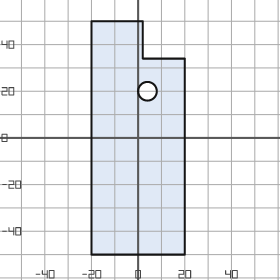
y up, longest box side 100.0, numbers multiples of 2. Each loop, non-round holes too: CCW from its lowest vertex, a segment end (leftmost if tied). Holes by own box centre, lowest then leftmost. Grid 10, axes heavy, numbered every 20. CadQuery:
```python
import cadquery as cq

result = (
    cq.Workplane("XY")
    .moveTo(-20.0, -50.0)
    .lineTo(20.0, -50.0)
    .lineTo(20.0, 34.0)
    .lineTo(2.0, 34.0)
    .lineTo(2.0, 50.0)
    .lineTo(-20.0, 50.0)
    .close()
    .moveTo(4.0, 20.0)
    .circle(4.0)
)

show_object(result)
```